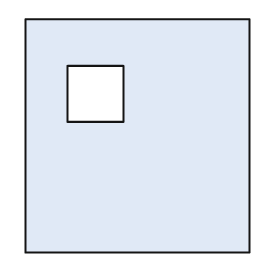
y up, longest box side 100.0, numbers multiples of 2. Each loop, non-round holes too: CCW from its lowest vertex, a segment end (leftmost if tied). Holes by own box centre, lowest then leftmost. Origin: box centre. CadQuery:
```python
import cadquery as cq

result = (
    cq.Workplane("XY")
    .moveTo(-48.0, -50.0)
    .lineTo(48.0, -50.0)
    .lineTo(48.0, 50.0)
    .lineTo(-48.0, 50.0)
    .close()
    .moveTo(-30.0, 6.0)
    .lineTo(-6.0, 6.0)
    .lineTo(-6.0, 30.0)
    .lineTo(-30.0, 30.0)
    .close()
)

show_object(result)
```